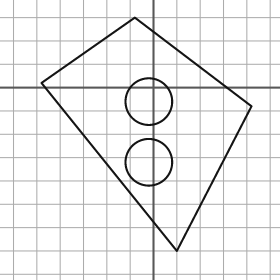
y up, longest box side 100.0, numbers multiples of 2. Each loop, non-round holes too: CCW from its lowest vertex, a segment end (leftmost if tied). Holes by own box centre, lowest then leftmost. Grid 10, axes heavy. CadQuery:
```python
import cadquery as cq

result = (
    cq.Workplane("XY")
    .moveTo(10.0, -70.0)
    .lineTo(42.0, -8.0)
    .lineTo(-8.0, 30.0)
    .lineTo(-48.0, 2.0)
    .close()
    .moveTo(-2.0, -32.0)
    .circle(10.0)
    .moveTo(-2.0, -6.0)
    .circle(10.0)
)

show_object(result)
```